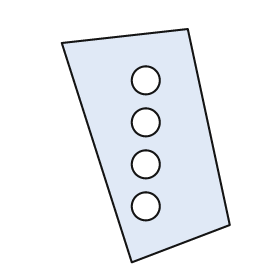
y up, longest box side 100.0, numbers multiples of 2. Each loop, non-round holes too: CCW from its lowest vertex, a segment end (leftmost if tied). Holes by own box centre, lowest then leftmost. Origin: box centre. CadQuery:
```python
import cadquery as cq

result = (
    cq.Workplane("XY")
    .moveTo(-6.0, -50.0)
    .lineTo(36.0, -34.0)
    .lineTo(18.0, 50.0)
    .lineTo(-36.0, 44.0)
    .close()
    .moveTo(0.0, -26.0)
    .circle(6.0)
    .moveTo(0.0, -8.0)
    .circle(6.0)
    .moveTo(0.0, 10.0)
    .circle(6.0)
    .moveTo(0.0, 28.0)
    .circle(6.0)
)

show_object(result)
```